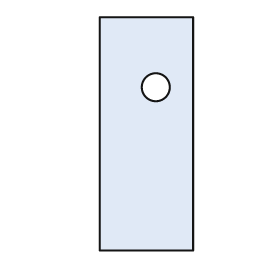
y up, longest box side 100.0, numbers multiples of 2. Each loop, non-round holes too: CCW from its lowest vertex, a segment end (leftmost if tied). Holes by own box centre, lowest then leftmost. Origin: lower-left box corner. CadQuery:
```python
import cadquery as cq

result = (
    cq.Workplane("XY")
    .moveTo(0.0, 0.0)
    .lineTo(40.0, 0.0)
    .lineTo(40.0, 100.0)
    .lineTo(0.0, 100.0)
    .close()
    .moveTo(24.0, 70.0)
    .circle(6.0)
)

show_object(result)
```